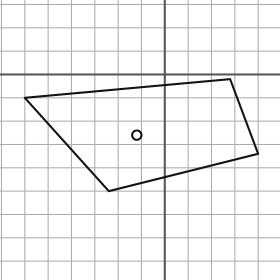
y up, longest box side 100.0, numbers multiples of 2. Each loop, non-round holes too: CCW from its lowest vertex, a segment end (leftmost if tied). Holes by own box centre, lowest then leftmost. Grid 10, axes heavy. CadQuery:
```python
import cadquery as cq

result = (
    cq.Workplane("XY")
    .moveTo(-24.0, -50.0)
    .lineTo(40.0, -34.0)
    .lineTo(28.0, -2.0)
    .lineTo(-60.0, -10.0)
    .close()
    .moveTo(-12.0, -26.0)
    .circle(2.0)
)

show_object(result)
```